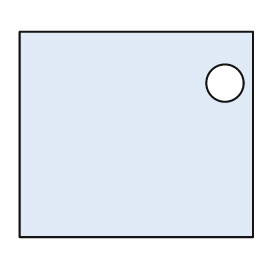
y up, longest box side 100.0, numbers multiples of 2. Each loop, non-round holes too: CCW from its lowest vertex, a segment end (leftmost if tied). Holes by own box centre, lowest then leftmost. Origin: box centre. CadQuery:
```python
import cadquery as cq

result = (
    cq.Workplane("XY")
    .moveTo(-50.0, -44.0)
    .lineTo(50.0, -44.0)
    .lineTo(50.0, 44.0)
    .lineTo(-50.0, 44.0)
    .close()
    .moveTo(38.0, 22.0)
    .circle(8.0)
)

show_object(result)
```